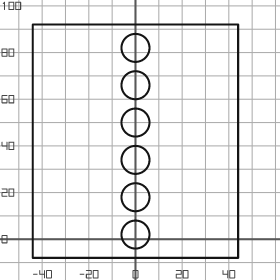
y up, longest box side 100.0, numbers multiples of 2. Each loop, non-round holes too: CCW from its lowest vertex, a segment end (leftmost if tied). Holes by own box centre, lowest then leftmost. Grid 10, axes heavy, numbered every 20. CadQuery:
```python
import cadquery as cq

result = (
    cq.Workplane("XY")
    .moveTo(-44.0, -8.0)
    .lineTo(44.0, -8.0)
    .lineTo(44.0, 92.0)
    .lineTo(-44.0, 92.0)
    .close()
    .moveTo(0.0, 2.0)
    .circle(6.0)
    .moveTo(0.0, 18.0)
    .circle(6.0)
    .moveTo(0.0, 34.0)
    .circle(6.0)
    .moveTo(0.0, 50.0)
    .circle(6.0)
    .moveTo(0.0, 66.0)
    .circle(6.0)
    .moveTo(0.0, 82.0)
    .circle(6.0)
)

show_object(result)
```